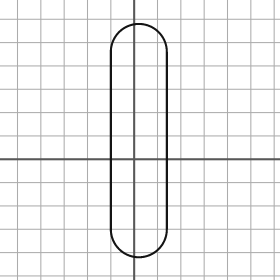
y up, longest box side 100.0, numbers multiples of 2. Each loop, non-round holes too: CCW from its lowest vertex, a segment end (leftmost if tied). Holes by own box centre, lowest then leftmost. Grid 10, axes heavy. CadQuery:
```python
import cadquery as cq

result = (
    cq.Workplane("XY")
    .moveTo(-10.0, -30.0)
    .threePointArc((2.0, -42.0), (14.0, -30.0))
    .lineTo(14.0, 46.0)
    .threePointArc((2.0, 58.0), (-10.0, 46.0))
    .close()
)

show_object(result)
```